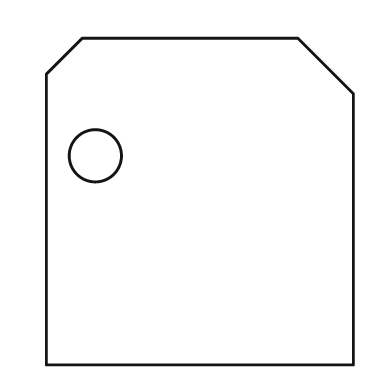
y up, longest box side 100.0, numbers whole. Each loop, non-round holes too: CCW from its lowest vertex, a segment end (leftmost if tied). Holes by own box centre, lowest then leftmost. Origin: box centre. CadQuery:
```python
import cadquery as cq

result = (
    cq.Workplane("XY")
    .moveTo(-47.0, -50.0)
    .lineTo(47.0, -50.0)
    .lineTo(47.0, 33.0)
    .lineTo(30.0, 50.0)
    .lineTo(-36.0, 50.0)
    .lineTo(-47.0, 39.0)
    .close()
    .moveTo(-32.0, 14.0)
    .circle(8.0)
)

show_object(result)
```